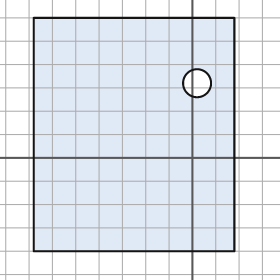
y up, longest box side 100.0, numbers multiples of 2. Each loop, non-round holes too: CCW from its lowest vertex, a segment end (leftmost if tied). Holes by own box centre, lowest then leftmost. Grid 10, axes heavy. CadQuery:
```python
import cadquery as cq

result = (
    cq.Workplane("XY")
    .moveTo(-68.0, -40.0)
    .lineTo(18.0, -40.0)
    .lineTo(18.0, 60.0)
    .lineTo(-68.0, 60.0)
    .close()
    .moveTo(2.0, 32.0)
    .circle(6.0)
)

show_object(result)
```